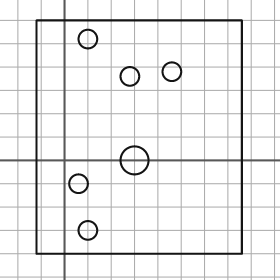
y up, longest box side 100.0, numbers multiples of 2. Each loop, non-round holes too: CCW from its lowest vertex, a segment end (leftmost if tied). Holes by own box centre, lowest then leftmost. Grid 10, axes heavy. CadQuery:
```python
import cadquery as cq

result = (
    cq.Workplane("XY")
    .moveTo(-12.0, -40.0)
    .lineTo(76.0, -40.0)
    .lineTo(76.0, 60.0)
    .lineTo(-12.0, 60.0)
    .close()
    .moveTo(10.0, -30.0)
    .circle(4.0)
    .moveTo(6.0, -10.0)
    .circle(4.0)
    .moveTo(30.0, 0.0)
    .circle(6.0)
    .moveTo(28.0, 36.0)
    .circle(4.0)
    .moveTo(46.0, 38.0)
    .circle(4.0)
    .moveTo(10.0, 52.0)
    .circle(4.0)
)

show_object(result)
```